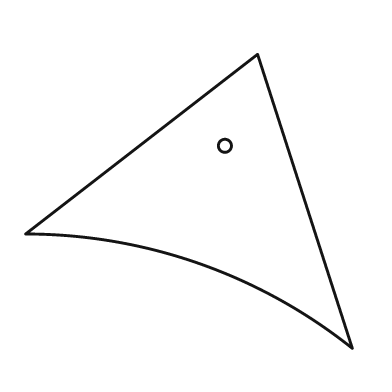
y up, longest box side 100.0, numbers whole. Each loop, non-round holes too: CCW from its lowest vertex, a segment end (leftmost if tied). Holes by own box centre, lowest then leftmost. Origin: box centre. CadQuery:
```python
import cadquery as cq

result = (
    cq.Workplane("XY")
    .moveTo(50.0, -45.0)
    .lineTo(21.0, 45.0)
    .lineTo(-50.0, -10.0)
    .threePointArc((3.0, -19.0), (50.0, -45.0))
    .close()
    .moveTo(11.0, 17.0)
    .circle(2.0)
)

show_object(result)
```